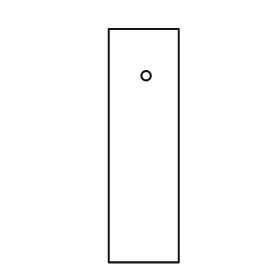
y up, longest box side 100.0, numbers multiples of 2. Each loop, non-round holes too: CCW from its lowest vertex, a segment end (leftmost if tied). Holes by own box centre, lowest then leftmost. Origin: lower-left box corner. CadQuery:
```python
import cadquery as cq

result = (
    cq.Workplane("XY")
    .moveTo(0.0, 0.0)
    .lineTo(30.0, 0.0)
    .lineTo(30.0, 100.0)
    .lineTo(0.0, 100.0)
    .close()
    .moveTo(16.0, 80.0)
    .circle(2.0)
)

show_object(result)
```